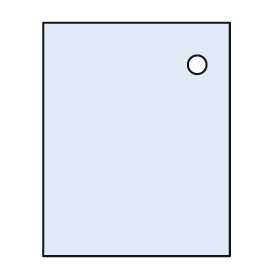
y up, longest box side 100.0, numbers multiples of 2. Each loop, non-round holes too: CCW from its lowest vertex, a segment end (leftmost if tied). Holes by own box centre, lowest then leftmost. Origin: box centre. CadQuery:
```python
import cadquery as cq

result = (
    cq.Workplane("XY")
    .moveTo(-40.0, -50.0)
    .lineTo(40.0, -50.0)
    .lineTo(40.0, 50.0)
    .lineTo(-40.0, 50.0)
    .close()
    .moveTo(26.0, 32.0)
    .circle(4.0)
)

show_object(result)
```